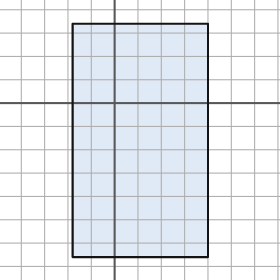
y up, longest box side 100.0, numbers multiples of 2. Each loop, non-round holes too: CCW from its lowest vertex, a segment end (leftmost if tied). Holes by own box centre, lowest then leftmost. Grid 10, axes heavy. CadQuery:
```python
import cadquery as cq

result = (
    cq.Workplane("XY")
    .moveTo(-18.0, -66.0)
    .lineTo(40.0, -66.0)
    .lineTo(40.0, 34.0)
    .lineTo(-18.0, 34.0)
    .close()
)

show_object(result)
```